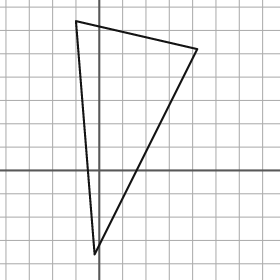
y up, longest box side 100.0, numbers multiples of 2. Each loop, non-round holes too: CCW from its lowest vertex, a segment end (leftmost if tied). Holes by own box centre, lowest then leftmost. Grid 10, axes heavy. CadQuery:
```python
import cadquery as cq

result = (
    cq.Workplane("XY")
    .moveTo(-2.0, -36.0)
    .lineTo(42.0, 52.0)
    .lineTo(-10.0, 64.0)
    .close()
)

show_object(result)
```